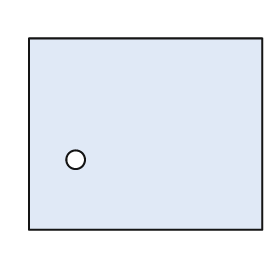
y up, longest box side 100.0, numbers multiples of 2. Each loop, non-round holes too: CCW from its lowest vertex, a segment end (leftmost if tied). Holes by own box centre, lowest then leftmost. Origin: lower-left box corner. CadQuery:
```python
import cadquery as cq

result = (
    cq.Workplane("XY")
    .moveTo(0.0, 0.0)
    .lineTo(100.0, 0.0)
    .lineTo(100.0, 82.0)
    .lineTo(0.0, 82.0)
    .close()
    .moveTo(20.0, 30.0)
    .circle(4.0)
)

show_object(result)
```